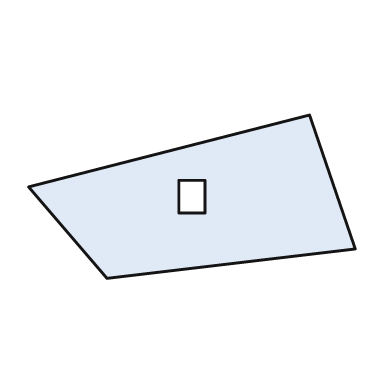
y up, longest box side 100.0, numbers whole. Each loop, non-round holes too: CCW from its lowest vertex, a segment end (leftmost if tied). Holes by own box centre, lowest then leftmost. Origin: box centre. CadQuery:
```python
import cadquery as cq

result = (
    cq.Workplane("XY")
    .moveTo(-26.0, -25.0)
    .lineTo(50.0, -16.0)
    .lineTo(36.0, 25.0)
    .lineTo(-50.0, 3.0)
    .close()
    .moveTo(-4.0, -5.0)
    .lineTo(4.0, -5.0)
    .lineTo(4.0, 5.0)
    .lineTo(-4.0, 5.0)
    .close()
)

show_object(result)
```